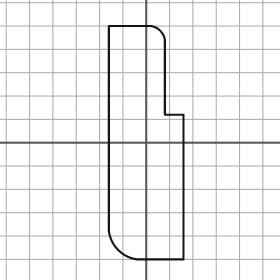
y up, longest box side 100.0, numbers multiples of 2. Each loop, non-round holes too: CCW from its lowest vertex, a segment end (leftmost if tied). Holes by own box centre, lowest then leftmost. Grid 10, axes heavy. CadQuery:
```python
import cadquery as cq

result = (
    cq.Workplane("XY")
    .moveTo(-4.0, -50.0)
    .lineTo(16.0, -50.0)
    .lineTo(16.0, 12.0)
    .lineTo(8.0, 12.0)
    .lineTo(8.0, 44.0)
    .threePointArc((6.0, 48.0), (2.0, 50.0))
    .lineTo(-16.0, 50.0)
    .lineTo(-16.0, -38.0)
    .threePointArc((-12.0, -46.0), (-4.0, -50.0))
    .close()
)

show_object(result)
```